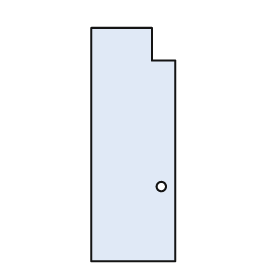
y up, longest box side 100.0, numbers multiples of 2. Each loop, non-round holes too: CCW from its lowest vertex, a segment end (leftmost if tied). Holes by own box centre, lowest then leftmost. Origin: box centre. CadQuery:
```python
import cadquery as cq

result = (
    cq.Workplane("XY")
    .moveTo(-18.0, -50.0)
    .lineTo(18.0, -50.0)
    .lineTo(18.0, 36.0)
    .lineTo(8.0, 36.0)
    .lineTo(8.0, 50.0)
    .lineTo(-18.0, 50.0)
    .close()
    .moveTo(12.0, -18.0)
    .circle(2.0)
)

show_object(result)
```